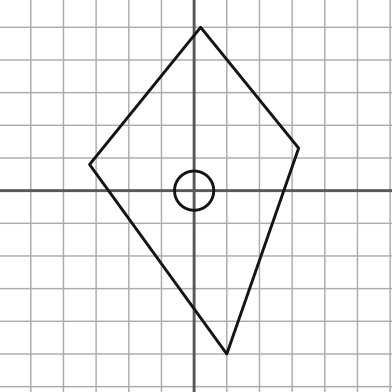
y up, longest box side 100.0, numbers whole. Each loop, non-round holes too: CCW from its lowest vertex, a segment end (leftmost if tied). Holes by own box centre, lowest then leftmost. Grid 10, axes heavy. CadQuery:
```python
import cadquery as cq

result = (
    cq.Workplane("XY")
    .moveTo(10.0, -50.0)
    .lineTo(32.0, 13.0)
    .lineTo(2.0, 50.0)
    .lineTo(-32.0, 8.0)
    .close()
    .moveTo(0.0, 0.0)
    .circle(6.0)
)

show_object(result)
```